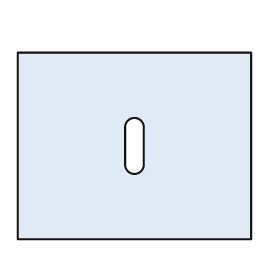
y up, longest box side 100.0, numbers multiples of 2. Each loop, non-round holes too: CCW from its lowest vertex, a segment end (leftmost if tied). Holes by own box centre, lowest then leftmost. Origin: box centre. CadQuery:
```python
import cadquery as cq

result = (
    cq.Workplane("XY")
    .moveTo(-50.0, -40.0)
    .lineTo(50.0, -40.0)
    .lineTo(50.0, 40.0)
    .lineTo(-50.0, 40.0)
    .close()
    .moveTo(-4.0, -8.0)
    .threePointArc((0.0, -12.0), (4.0, -8.0))
    .lineTo(4.0, 8.0)
    .threePointArc((0.0, 12.0), (-4.0, 8.0))
    .close()
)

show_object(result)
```